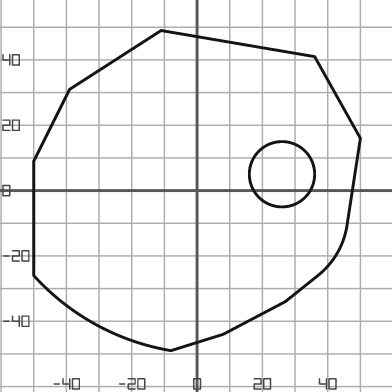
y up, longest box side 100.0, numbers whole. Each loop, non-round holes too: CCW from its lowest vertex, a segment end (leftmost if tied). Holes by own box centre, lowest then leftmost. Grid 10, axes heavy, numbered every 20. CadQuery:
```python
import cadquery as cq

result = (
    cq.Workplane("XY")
    .moveTo(-8.0, -49.0)
    .lineTo(8.0, -44.0)
    .lineTo(27.0, -34.0)
    .lineTo(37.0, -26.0)
    .threePointArc((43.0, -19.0), (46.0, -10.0))
    .lineTo(50.0, 16.0)
    .lineTo(36.0, 41.0)
    .lineTo(-11.0, 49.0)
    .lineTo(-39.0, 31.0)
    .lineTo(-50.0, 9.0)
    .lineTo(-50.0, -26.0)
    .threePointArc((-31.0, -41.0), (-8.0, -49.0))
    .close()
    .moveTo(26.0, 5.0)
    .circle(10.0)
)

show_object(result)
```